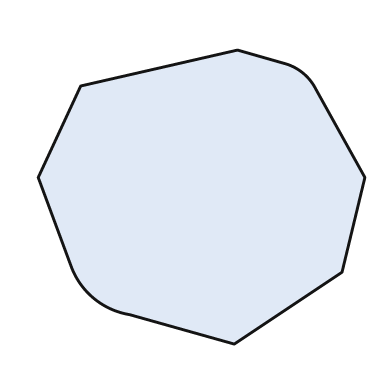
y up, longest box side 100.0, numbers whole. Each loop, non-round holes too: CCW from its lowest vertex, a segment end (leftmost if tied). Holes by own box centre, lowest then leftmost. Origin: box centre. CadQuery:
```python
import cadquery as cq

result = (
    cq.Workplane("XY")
    .moveTo(10.0, -45.0)
    .lineTo(43.0, -23.0)
    .lineTo(50.0, 6.0)
    .lineTo(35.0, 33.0)
    .threePointArc((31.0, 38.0), (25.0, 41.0))
    .lineTo(11.0, 45.0)
    .lineTo(-37.0, 34.0)
    .lineTo(-50.0, 6.0)
    .lineTo(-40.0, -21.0)
    .threePointArc((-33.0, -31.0), (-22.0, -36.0))
    .close()
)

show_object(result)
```